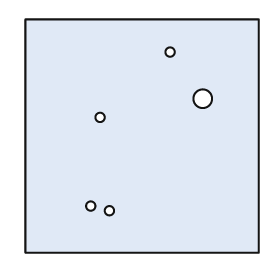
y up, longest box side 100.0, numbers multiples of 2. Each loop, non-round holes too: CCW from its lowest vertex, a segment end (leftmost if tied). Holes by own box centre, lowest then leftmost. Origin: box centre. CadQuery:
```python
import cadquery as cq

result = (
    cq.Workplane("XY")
    .moveTo(-50.0, -50.0)
    .lineTo(50.0, -50.0)
    .lineTo(50.0, 50.0)
    .lineTo(-50.0, 50.0)
    .close()
    .moveTo(-14.0, -32.0)
    .circle(2.0)
    .moveTo(-22.0, -30.0)
    .circle(2.0)
    .moveTo(-18.0, 8.0)
    .circle(2.0)
    .moveTo(26.0, 16.0)
    .circle(4.0)
    .moveTo(12.0, 36.0)
    .circle(2.0)
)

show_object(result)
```